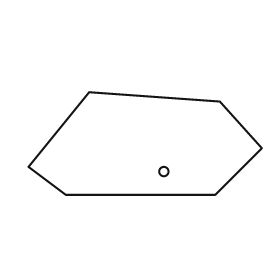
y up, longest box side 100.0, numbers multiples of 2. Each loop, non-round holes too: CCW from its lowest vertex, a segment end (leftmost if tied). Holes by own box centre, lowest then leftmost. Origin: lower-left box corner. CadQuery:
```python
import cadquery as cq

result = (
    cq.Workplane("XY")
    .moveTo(16.0, 0.0)
    .lineTo(80.0, 0.0)
    .lineTo(100.0, 20.0)
    .lineTo(82.0, 40.0)
    .lineTo(26.0, 44.0)
    .lineTo(0.0, 12.0)
    .close()
    .moveTo(58.0, 10.0)
    .circle(2.0)
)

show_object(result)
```